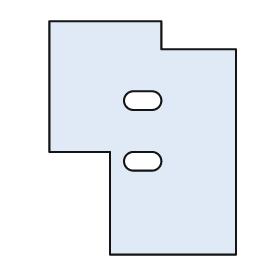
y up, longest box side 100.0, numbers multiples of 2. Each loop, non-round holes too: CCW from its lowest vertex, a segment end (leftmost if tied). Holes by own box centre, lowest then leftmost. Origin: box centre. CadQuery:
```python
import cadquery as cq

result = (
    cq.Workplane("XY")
    .moveTo(-14.0, -50.0)
    .lineTo(40.0, -50.0)
    .lineTo(40.0, 38.0)
    .lineTo(8.0, 38.0)
    .lineTo(8.0, 50.0)
    .lineTo(-40.0, 50.0)
    .lineTo(-40.0, -6.0)
    .lineTo(-14.0, -6.0)
    .close()
    .moveTo(-4.0, -14.0)
    .lineTo(4.0, -14.0)
    .threePointArc((8.0, -10.0), (4.0, -6.0))
    .lineTo(-4.0, -6.0)
    .threePointArc((-8.0, -10.0), (-4.0, -14.0))
    .close()
    .moveTo(-4.0, 12.0)
    .lineTo(4.0, 12.0)
    .threePointArc((8.0, 16.0), (4.0, 20.0))
    .lineTo(-4.0, 20.0)
    .threePointArc((-8.0, 16.0), (-4.0, 12.0))
    .close()
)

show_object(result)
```